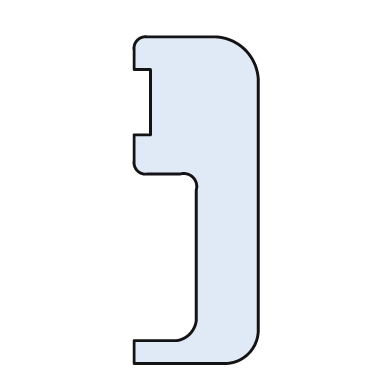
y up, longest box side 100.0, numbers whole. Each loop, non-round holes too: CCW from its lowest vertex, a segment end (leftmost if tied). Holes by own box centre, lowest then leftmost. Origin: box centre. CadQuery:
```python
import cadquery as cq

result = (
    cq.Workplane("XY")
    .moveTo(-19.0, -50.0)
    .lineTo(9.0, -50.0)
    .threePointArc((16.0, -47.0), (19.0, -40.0))
    .lineTo(19.0, 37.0)
    .threePointArc((15.0, 46.0), (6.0, 50.0))
    .lineTo(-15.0, 50.0)
    .threePointArc((-18.0, 49.0), (-19.0, 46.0))
    .lineTo(-19.0, 40.0)
    .lineTo(-14.0, 40.0)
    .lineTo(-14.0, 20.0)
    .lineTo(-19.0, 20.0)
    .lineTo(-19.0, 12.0)
    .threePointArc((-18.0, 9.0), (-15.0, 8.0))
    .lineTo(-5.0, 8.0)
    .threePointArc((-1.0, 7.0), (0.0, 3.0))
    .lineTo(0.0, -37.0)
    .threePointArc((-2.0, -41.0), (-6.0, -43.0))
    .lineTo(-19.0, -43.0)
    .close()
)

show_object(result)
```